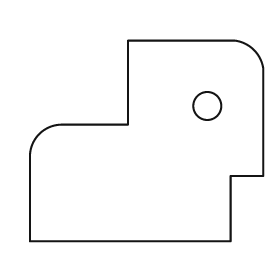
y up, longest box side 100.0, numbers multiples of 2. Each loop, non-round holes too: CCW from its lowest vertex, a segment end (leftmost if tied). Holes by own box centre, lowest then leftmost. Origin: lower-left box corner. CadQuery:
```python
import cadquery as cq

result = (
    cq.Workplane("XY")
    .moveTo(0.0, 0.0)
    .lineTo(86.0, 0.0)
    .lineTo(86.0, 28.0)
    .lineTo(100.0, 28.0)
    .lineTo(100.0, 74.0)
    .threePointArc((96.0, 82.0), (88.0, 86.0))
    .lineTo(42.0, 86.0)
    .lineTo(42.0, 50.0)
    .lineTo(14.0, 50.0)
    .threePointArc((4.0, 46.0), (0.0, 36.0))
    .close()
    .moveTo(76.0, 58.0)
    .circle(6.0)
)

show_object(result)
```